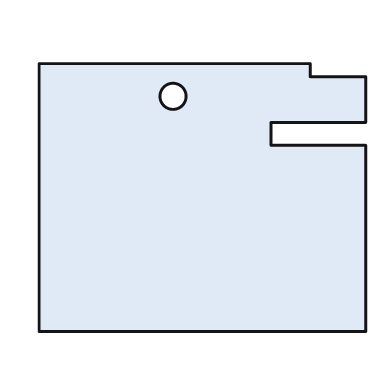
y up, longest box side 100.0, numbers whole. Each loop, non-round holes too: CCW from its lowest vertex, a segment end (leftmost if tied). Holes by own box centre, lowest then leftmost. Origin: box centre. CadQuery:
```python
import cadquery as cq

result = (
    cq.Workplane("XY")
    .moveTo(-50.0, -41.0)
    .lineTo(50.0, -41.0)
    .lineTo(50.0, 16.0)
    .lineTo(21.0, 16.0)
    .lineTo(21.0, 23.0)
    .lineTo(50.0, 23.0)
    .lineTo(50.0, 37.0)
    .lineTo(33.0, 37.0)
    .lineTo(33.0, 41.0)
    .lineTo(-50.0, 41.0)
    .close()
    .moveTo(-9.0, 31.0)
    .circle(4.0)
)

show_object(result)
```